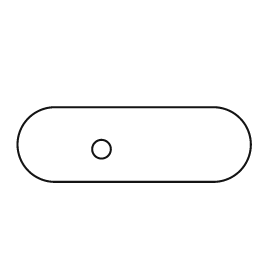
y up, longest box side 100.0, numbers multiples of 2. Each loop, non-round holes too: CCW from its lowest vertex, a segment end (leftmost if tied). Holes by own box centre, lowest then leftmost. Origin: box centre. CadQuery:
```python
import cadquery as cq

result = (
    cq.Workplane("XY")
    .moveTo(-34.0, -16.0)
    .lineTo(34.0, -16.0)
    .threePointArc((50.0, 0.0), (34.0, 16.0))
    .lineTo(-34.0, 16.0)
    .threePointArc((-50.0, 0.0), (-34.0, -16.0))
    .close()
    .moveTo(-14.0, -2.0)
    .circle(4.0)
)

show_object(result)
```